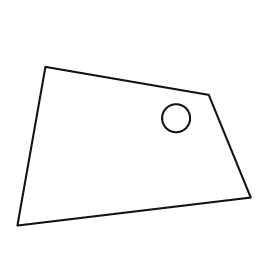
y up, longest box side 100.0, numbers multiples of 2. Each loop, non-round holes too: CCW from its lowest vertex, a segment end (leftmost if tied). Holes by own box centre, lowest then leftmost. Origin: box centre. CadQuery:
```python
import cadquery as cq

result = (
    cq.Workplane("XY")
    .moveTo(-50.0, -34.0)
    .lineTo(50.0, -22.0)
    .lineTo(32.0, 22.0)
    .lineTo(-38.0, 34.0)
    .close()
    .moveTo(18.0, 12.0)
    .circle(6.0)
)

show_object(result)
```